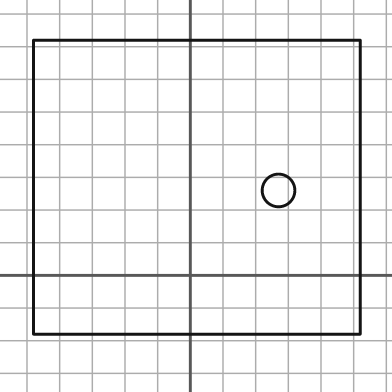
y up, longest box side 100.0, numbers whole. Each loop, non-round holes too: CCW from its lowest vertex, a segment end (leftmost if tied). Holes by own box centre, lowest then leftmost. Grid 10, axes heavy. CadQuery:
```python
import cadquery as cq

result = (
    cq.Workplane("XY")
    .moveTo(-48.0, -18.0)
    .lineTo(52.0, -18.0)
    .lineTo(52.0, 72.0)
    .lineTo(-48.0, 72.0)
    .close()
    .moveTo(27.0, 26.0)
    .circle(5.0)
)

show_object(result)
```